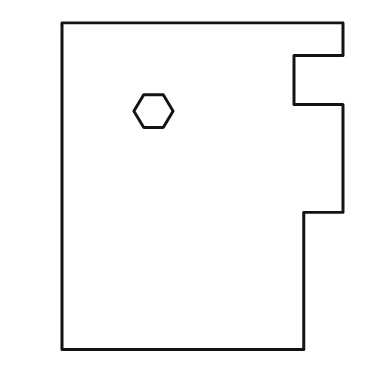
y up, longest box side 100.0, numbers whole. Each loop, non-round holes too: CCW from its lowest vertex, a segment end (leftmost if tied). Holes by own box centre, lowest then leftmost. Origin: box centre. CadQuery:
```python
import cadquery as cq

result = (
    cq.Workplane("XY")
    .moveTo(-43.0, -50.0)
    .lineTo(31.0, -50.0)
    .lineTo(31.0, -8.0)
    .lineTo(43.0, -8.0)
    .lineTo(43.0, 25.0)
    .lineTo(28.0, 25.0)
    .lineTo(28.0, 40.0)
    .lineTo(43.0, 40.0)
    .lineTo(43.0, 50.0)
    .lineTo(-43.0, 50.0)
    .close()
    .moveTo(-18.0, 18.0)
    .lineTo(-12.0, 18.0)
    .lineTo(-9.0, 23.0)
    .lineTo(-12.0, 28.0)
    .lineTo(-18.0, 28.0)
    .lineTo(-21.0, 23.0)
    .close()
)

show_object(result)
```